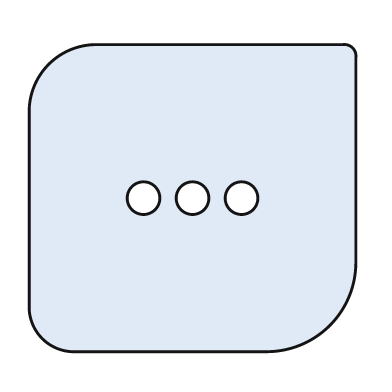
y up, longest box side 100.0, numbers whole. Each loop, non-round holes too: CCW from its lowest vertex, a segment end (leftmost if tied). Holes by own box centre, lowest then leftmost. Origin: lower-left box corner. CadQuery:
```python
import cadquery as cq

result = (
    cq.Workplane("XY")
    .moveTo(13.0, 0.0)
    .lineTo(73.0, 0.0)
    .threePointArc((92.0, 8.0), (100.0, 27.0))
    .lineTo(100.0, 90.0)
    .threePointArc((99.0, 93.0), (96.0, 94.0))
    .lineTo(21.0, 94.0)
    .threePointArc((6.0, 88.0), (0.0, 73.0))
    .lineTo(0.0, 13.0)
    .threePointArc((4.0, 4.0), (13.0, 0.0))
    .close()
    .moveTo(35.0, 47.0)
    .circle(5.0)
    .moveTo(50.0, 47.0)
    .circle(5.0)
    .moveTo(65.0, 47.0)
    .circle(5.0)
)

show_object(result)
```